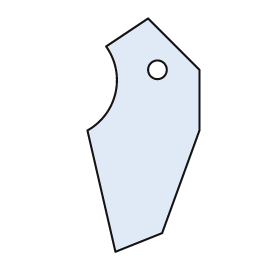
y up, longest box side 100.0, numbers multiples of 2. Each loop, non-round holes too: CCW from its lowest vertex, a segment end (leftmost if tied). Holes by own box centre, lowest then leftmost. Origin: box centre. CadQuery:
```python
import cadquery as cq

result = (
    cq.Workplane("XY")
    .moveTo(-12.0, -50.0)
    .lineTo(8.0, -42.0)
    .lineTo(24.0, 2.0)
    .lineTo(24.0, 28.0)
    .lineTo(2.0, 50.0)
    .lineTo(-16.0, 38.0)
    .threePointArc((-12.0, 18.0), (-24.0, 2.0))
    .close()
    .moveTo(6.0, 28.0)
    .circle(4.0)
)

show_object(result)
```